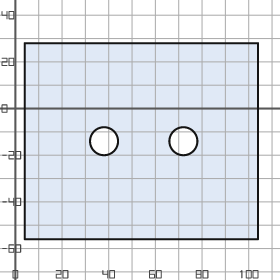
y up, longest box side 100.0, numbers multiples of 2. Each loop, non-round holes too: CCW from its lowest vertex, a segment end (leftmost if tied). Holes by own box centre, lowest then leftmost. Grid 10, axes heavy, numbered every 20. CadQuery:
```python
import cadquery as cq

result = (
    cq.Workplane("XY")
    .moveTo(4.0, -56.0)
    .lineTo(104.0, -56.0)
    .lineTo(104.0, 28.0)
    .lineTo(4.0, 28.0)
    .close()
    .moveTo(38.0, -14.0)
    .circle(6.0)
    .moveTo(72.0, -14.0)
    .circle(6.0)
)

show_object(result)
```